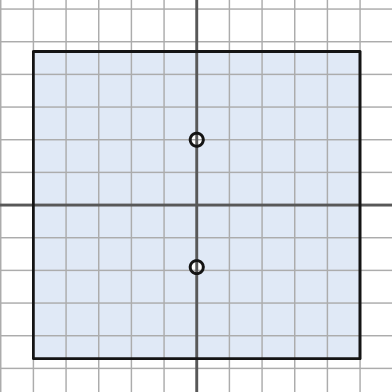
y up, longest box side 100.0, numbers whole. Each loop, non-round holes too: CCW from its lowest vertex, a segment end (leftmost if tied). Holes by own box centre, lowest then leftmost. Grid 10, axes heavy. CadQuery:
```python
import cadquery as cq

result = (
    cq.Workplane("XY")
    .moveTo(-50.0, -47.0)
    .lineTo(50.0, -47.0)
    .lineTo(50.0, 47.0)
    .lineTo(-50.0, 47.0)
    .close()
    .moveTo(0.0, -19.0)
    .circle(2.0)
    .moveTo(0.0, 20.0)
    .circle(2.0)
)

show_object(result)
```